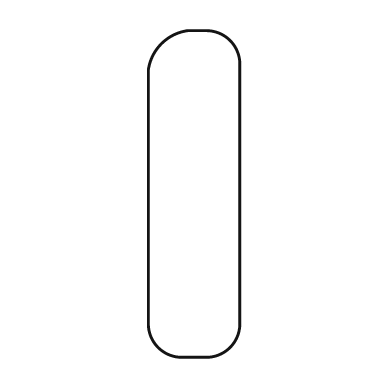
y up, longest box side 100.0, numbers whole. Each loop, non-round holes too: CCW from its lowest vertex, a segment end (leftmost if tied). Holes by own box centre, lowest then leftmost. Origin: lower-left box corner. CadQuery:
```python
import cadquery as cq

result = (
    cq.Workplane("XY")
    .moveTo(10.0, 0.0)
    .lineTo(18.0, 0.0)
    .threePointArc((25.0, 3.0), (28.0, 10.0))
    .lineTo(28.0, 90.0)
    .threePointArc((25.0, 97.0), (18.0, 100.0))
    .lineTo(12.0, 100.0)
    .threePointArc((4.0, 96.0), (0.0, 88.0))
    .lineTo(0.0, 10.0)
    .threePointArc((3.0, 3.0), (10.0, 0.0))
    .close()
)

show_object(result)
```